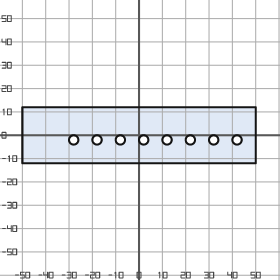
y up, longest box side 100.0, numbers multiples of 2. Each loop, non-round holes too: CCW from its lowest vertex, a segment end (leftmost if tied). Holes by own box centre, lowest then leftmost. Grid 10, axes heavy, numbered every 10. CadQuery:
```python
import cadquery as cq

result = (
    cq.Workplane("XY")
    .moveTo(-50.0, -12.0)
    .lineTo(50.0, -12.0)
    .lineTo(50.0, 12.0)
    .lineTo(-50.0, 12.0)
    .close()
    .moveTo(-28.0, -2.0)
    .circle(2.0)
    .moveTo(-18.0, -2.0)
    .circle(2.0)
    .moveTo(-8.0, -2.0)
    .circle(2.0)
    .moveTo(2.0, -2.0)
    .circle(2.0)
    .moveTo(12.0, -2.0)
    .circle(2.0)
    .moveTo(22.0, -2.0)
    .circle(2.0)
    .moveTo(32.0, -2.0)
    .circle(2.0)
    .moveTo(42.0, -2.0)
    .circle(2.0)
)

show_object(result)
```